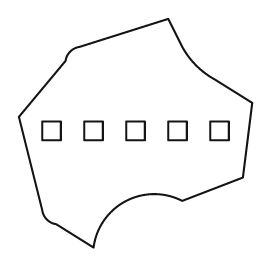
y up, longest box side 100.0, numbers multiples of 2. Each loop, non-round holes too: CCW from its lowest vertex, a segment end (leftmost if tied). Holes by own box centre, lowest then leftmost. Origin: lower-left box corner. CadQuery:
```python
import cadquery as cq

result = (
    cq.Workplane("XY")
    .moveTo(32.0, 0.0)
    .threePointArc((46.0, 20.0), (70.0, 20.0))
    .lineTo(96.0, 30.0)
    .lineTo(100.0, 62.0)
    .lineTo(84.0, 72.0)
    .threePointArc((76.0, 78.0), (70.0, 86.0))
    .lineTo(64.0, 98.0)
    .lineTo(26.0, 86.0)
    .threePointArc((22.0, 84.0), (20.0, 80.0))
    .lineTo(0.0, 56.0)
    .lineTo(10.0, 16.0)
    .threePointArc((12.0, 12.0), (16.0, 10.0))
    .close()
    .moveTo(10.0, 46.0)
    .lineTo(18.0, 46.0)
    .lineTo(18.0, 54.0)
    .lineTo(10.0, 54.0)
    .close()
    .moveTo(28.0, 46.0)
    .lineTo(36.0, 46.0)
    .lineTo(36.0, 54.0)
    .lineTo(28.0, 54.0)
    .close()
    .moveTo(46.0, 46.0)
    .lineTo(54.0, 46.0)
    .lineTo(54.0, 54.0)
    .lineTo(46.0, 54.0)
    .close()
    .moveTo(64.0, 46.0)
    .lineTo(72.0, 46.0)
    .lineTo(72.0, 54.0)
    .lineTo(64.0, 54.0)
    .close()
    .moveTo(82.0, 46.0)
    .lineTo(90.0, 46.0)
    .lineTo(90.0, 54.0)
    .lineTo(82.0, 54.0)
    .close()
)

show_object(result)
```